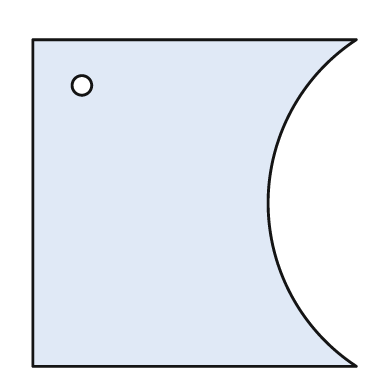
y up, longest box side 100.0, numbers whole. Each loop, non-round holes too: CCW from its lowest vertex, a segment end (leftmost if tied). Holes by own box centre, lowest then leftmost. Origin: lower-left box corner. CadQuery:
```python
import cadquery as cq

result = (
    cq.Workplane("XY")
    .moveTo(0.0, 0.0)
    .lineTo(99.0, 0.0)
    .threePointArc((72.0, 50.0), (99.0, 100.0))
    .lineTo(0.0, 100.0)
    .close()
    .moveTo(15.0, 86.0)
    .circle(3.0)
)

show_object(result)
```